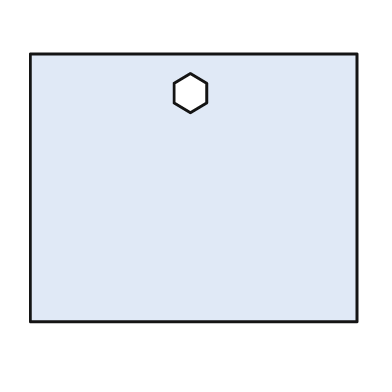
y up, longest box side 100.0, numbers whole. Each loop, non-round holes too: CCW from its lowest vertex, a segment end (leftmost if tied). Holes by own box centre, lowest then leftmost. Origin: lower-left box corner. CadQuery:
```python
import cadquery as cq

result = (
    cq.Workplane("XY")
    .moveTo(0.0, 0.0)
    .lineTo(100.0, 0.0)
    .lineTo(100.0, 82.0)
    .lineTo(0.0, 82.0)
    .close()
    .moveTo(49.0, 64.0)
    .lineTo(54.0, 67.0)
    .lineTo(54.0, 73.0)
    .lineTo(49.0, 76.0)
    .lineTo(44.0, 73.0)
    .lineTo(44.0, 67.0)
    .close()
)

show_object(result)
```